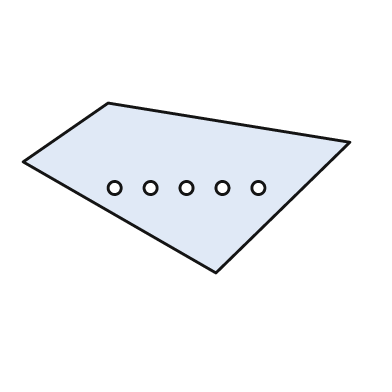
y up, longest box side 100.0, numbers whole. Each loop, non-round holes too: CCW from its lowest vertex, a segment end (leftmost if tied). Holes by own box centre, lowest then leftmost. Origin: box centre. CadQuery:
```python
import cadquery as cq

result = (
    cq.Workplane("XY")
    .moveTo(9.0, -26.0)
    .lineTo(50.0, 14.0)
    .lineTo(-24.0, 26.0)
    .lineTo(-50.0, 8.0)
    .close()
    .moveTo(-22.0, 0.0)
    .circle(2.0)
    .moveTo(-11.0, 0.0)
    .circle(2.0)
    .moveTo(0.0, 0.0)
    .circle(2.0)
    .moveTo(11.0, 0.0)
    .circle(2.0)
    .moveTo(22.0, 0.0)
    .circle(2.0)
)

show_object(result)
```